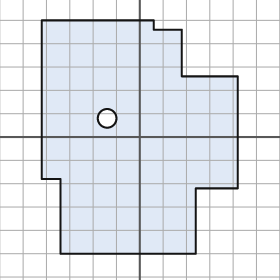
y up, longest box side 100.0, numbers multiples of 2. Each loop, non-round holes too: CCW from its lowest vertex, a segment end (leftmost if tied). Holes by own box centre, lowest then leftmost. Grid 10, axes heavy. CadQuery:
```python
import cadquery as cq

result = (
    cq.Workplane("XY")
    .moveTo(-34.0, -50.0)
    .lineTo(24.0, -50.0)
    .lineTo(24.0, -22.0)
    .lineTo(42.0, -22.0)
    .lineTo(42.0, 26.0)
    .lineTo(18.0, 26.0)
    .lineTo(18.0, 46.0)
    .lineTo(6.0, 46.0)
    .lineTo(6.0, 50.0)
    .lineTo(-42.0, 50.0)
    .lineTo(-42.0, -18.0)
    .lineTo(-34.0, -18.0)
    .close()
    .moveTo(-14.0, 8.0)
    .circle(4.0)
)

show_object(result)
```